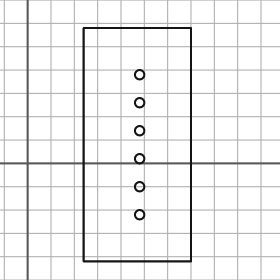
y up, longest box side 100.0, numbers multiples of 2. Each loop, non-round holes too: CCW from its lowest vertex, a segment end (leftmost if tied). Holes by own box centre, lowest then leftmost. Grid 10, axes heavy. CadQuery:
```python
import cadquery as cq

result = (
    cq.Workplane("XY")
    .moveTo(24.0, -42.0)
    .lineTo(70.0, -42.0)
    .lineTo(70.0, 58.0)
    .lineTo(24.0, 58.0)
    .close()
    .moveTo(48.0, -22.0)
    .circle(2.0)
    .moveTo(48.0, -10.0)
    .circle(2.0)
    .moveTo(48.0, 2.0)
    .circle(2.0)
    .moveTo(48.0, 14.0)
    .circle(2.0)
    .moveTo(48.0, 26.0)
    .circle(2.0)
    .moveTo(48.0, 38.0)
    .circle(2.0)
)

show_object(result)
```